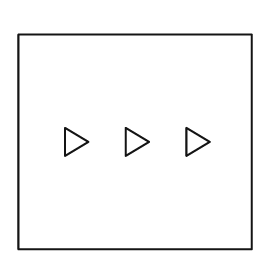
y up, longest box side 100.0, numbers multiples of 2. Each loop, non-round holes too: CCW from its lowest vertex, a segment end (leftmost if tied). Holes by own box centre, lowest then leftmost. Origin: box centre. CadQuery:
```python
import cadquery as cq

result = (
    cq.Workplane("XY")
    .moveTo(-50.0, -46.0)
    .lineTo(50.0, -46.0)
    .lineTo(50.0, 46.0)
    .lineTo(-50.0, 46.0)
    .close()
    .moveTo(-30.0, -6.0)
    .lineTo(-20.0, 0.0)
    .lineTo(-30.0, 6.0)
    .close()
    .moveTo(-4.0, -6.0)
    .lineTo(6.0, 0.0)
    .lineTo(-4.0, 6.0)
    .close()
    .moveTo(22.0, -6.0)
    .lineTo(32.0, 0.0)
    .lineTo(22.0, 6.0)
    .close()
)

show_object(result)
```